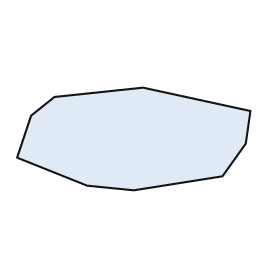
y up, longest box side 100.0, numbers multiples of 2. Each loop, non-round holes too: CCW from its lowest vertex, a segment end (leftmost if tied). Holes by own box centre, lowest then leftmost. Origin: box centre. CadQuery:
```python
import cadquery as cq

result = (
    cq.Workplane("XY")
    .moveTo(0.0, -22.0)
    .lineTo(38.0, -16.0)
    .lineTo(48.0, -2.0)
    .lineTo(50.0, 12.0)
    .lineTo(4.0, 22.0)
    .lineTo(-34.0, 18.0)
    .lineTo(-44.0, 10.0)
    .lineTo(-50.0, -8.0)
    .lineTo(-20.0, -20.0)
    .close()
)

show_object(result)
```